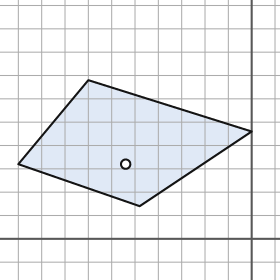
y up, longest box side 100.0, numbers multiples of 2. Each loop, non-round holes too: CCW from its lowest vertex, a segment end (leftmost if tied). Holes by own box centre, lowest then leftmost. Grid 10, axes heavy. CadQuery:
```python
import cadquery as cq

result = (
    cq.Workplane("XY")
    .moveTo(-48.0, 14.0)
    .lineTo(0.0, 46.0)
    .lineTo(-70.0, 68.0)
    .lineTo(-100.0, 32.0)
    .close()
    .moveTo(-54.0, 32.0)
    .circle(2.0)
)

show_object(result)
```